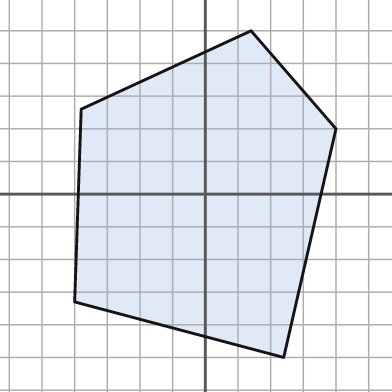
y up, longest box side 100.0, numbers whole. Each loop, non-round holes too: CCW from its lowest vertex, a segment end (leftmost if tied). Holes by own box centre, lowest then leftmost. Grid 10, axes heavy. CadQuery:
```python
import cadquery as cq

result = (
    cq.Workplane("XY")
    .moveTo(24.0, -50.0)
    .lineTo(40.0, 20.0)
    .lineTo(14.0, 50.0)
    .lineTo(-38.0, 26.0)
    .lineTo(-40.0, -33.0)
    .close()
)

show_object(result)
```